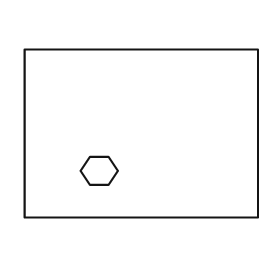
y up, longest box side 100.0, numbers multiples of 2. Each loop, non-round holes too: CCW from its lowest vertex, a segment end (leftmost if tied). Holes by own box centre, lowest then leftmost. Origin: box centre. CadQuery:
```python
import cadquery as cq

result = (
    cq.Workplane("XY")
    .moveTo(-50.0, -36.0)
    .lineTo(50.0, -36.0)
    .lineTo(50.0, 36.0)
    .lineTo(-50.0, 36.0)
    .close()
    .moveTo(-22.0, -22.0)
    .lineTo(-14.0, -22.0)
    .lineTo(-10.0, -16.0)
    .lineTo(-14.0, -10.0)
    .lineTo(-22.0, -10.0)
    .lineTo(-26.0, -16.0)
    .close()
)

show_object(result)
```